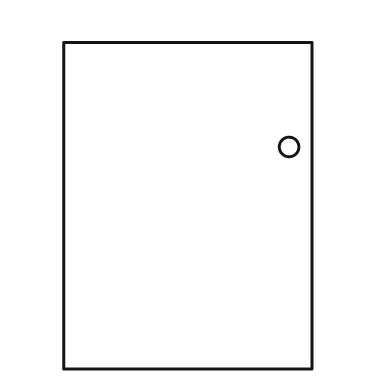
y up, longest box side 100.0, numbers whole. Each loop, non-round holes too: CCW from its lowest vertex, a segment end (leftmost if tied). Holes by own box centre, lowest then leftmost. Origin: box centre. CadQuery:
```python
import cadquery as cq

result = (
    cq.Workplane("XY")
    .moveTo(-38.0, -50.0)
    .lineTo(38.0, -50.0)
    .lineTo(38.0, 50.0)
    .lineTo(-38.0, 50.0)
    .close()
    .moveTo(31.0, 18.0)
    .circle(3.0)
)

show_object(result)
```